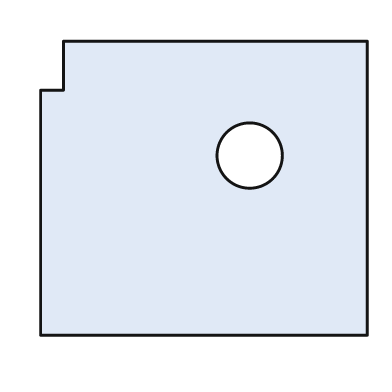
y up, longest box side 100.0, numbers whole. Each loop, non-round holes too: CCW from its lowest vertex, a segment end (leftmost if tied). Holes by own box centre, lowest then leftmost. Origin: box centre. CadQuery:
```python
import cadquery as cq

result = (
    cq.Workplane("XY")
    .moveTo(-50.0, -45.0)
    .lineTo(50.0, -45.0)
    .lineTo(50.0, 45.0)
    .lineTo(-43.0, 45.0)
    .lineTo(-43.0, 30.0)
    .lineTo(-50.0, 30.0)
    .close()
    .moveTo(14.0, 10.0)
    .circle(10.0)
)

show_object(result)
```